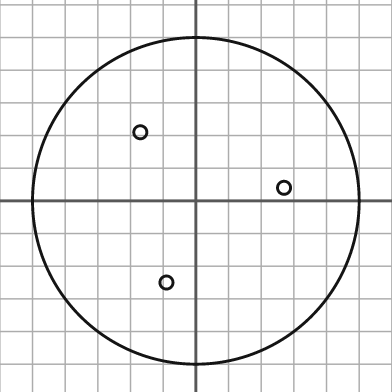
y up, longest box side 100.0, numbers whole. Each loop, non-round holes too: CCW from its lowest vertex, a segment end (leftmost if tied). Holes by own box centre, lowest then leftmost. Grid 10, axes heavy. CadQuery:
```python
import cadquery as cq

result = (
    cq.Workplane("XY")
    .moveTo(0.0, 0.0)
    .circle(50.0)
    .moveTo(-9.0, -25.0)
    .circle(2.0)
    .moveTo(27.0, 4.0)
    .circle(2.0)
    .moveTo(-17.0, 21.0)
    .circle(2.0)
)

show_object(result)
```